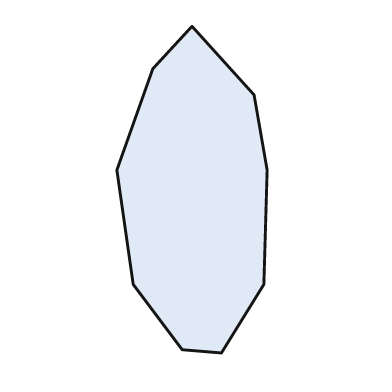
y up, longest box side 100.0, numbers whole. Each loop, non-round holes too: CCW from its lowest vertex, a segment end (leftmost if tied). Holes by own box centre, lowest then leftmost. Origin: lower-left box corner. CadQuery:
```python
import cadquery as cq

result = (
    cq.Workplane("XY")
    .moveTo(32.0, 0.0)
    .lineTo(45.0, 21.0)
    .lineTo(46.0, 56.0)
    .lineTo(42.0, 79.0)
    .lineTo(23.0, 100.0)
    .lineTo(11.0, 87.0)
    .lineTo(0.0, 56.0)
    .lineTo(5.0, 21.0)
    .lineTo(20.0, 1.0)
    .close()
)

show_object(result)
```